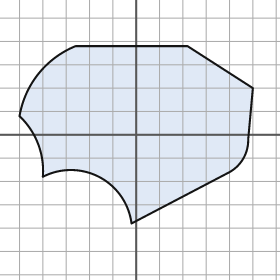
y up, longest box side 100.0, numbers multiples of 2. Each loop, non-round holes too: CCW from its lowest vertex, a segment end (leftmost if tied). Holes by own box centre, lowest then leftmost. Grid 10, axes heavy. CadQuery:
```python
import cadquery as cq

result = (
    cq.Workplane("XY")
    .moveTo(-2.0, -38.0)
    .lineTo(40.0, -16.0)
    .threePointArc((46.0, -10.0), (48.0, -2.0))
    .lineTo(50.0, 20.0)
    .lineTo(22.0, 38.0)
    .lineTo(-26.0, 38.0)
    .threePointArc((-42.0, 26.0), (-50.0, 8.0))
    .threePointArc((-42.0, -4.0), (-40.0, -18.0))
    .threePointArc((-16.0, -18.0), (-2.0, -38.0))
    .close()
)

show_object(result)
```